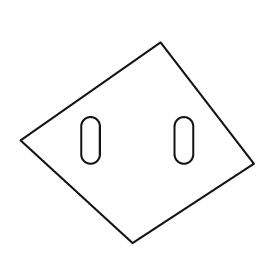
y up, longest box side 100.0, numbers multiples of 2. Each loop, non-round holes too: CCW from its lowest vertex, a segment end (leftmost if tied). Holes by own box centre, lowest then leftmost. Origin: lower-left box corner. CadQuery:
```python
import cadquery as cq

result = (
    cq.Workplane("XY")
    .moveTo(48.0, 0.0)
    .lineTo(100.0, 34.0)
    .lineTo(60.0, 86.0)
    .lineTo(0.0, 44.0)
    .close()
    .moveTo(26.0, 38.0)
    .threePointArc((30.0, 34.0), (34.0, 38.0))
    .lineTo(34.0, 50.0)
    .threePointArc((30.0, 54.0), (26.0, 50.0))
    .close()
    .moveTo(66.0, 38.0)
    .threePointArc((70.0, 34.0), (74.0, 38.0))
    .lineTo(74.0, 50.0)
    .threePointArc((70.0, 54.0), (66.0, 50.0))
    .close()
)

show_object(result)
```